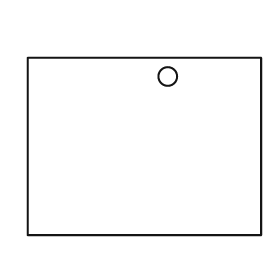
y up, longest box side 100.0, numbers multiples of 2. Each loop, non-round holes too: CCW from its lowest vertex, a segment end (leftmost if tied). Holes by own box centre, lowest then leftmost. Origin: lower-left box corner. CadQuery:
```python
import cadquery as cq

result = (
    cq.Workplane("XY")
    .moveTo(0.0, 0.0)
    .lineTo(100.0, 0.0)
    .lineTo(100.0, 76.0)
    .lineTo(0.0, 76.0)
    .close()
    .moveTo(60.0, 68.0)
    .circle(4.0)
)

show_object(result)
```